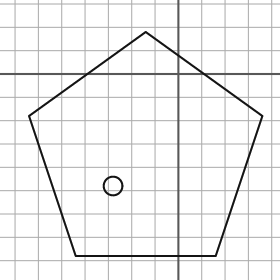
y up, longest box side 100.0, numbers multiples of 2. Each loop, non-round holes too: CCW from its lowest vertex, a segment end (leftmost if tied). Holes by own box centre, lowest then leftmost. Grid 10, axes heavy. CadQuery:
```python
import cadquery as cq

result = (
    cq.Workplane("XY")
    .moveTo(-44.0, -78.0)
    .lineTo(16.0, -78.0)
    .lineTo(36.0, -18.0)
    .lineTo(-14.0, 18.0)
    .lineTo(-64.0, -18.0)
    .close()
    .moveTo(-28.0, -48.0)
    .circle(4.0)
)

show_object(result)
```